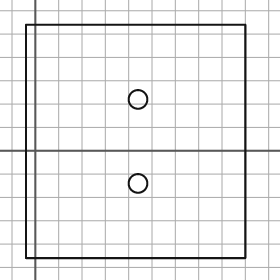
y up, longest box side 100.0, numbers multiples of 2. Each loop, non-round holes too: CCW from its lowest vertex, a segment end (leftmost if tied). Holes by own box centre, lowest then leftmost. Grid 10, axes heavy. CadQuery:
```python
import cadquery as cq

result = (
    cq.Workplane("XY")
    .moveTo(-4.0, -46.0)
    .lineTo(90.0, -46.0)
    .lineTo(90.0, 54.0)
    .lineTo(-4.0, 54.0)
    .close()
    .moveTo(44.0, -14.0)
    .circle(4.0)
    .moveTo(44.0, 22.0)
    .circle(4.0)
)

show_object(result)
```